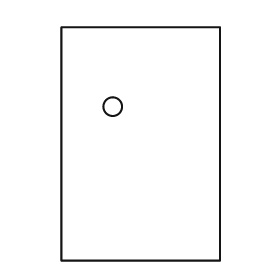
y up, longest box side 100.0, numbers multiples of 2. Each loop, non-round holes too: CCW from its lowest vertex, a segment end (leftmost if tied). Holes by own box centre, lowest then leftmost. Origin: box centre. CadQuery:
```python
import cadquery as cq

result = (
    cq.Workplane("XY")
    .moveTo(-34.0, -50.0)
    .lineTo(34.0, -50.0)
    .lineTo(34.0, 50.0)
    .lineTo(-34.0, 50.0)
    .close()
    .moveTo(-12.0, 16.0)
    .circle(4.0)
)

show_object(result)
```